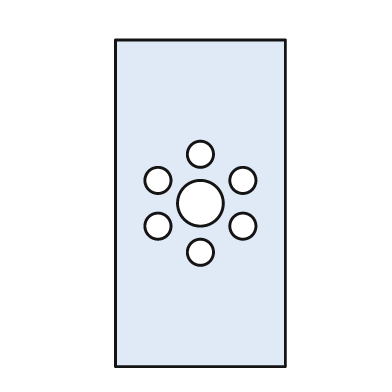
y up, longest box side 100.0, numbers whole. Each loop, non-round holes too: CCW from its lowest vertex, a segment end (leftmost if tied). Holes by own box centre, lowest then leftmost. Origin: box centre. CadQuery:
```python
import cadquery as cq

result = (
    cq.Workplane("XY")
    .moveTo(-26.0, -50.0)
    .lineTo(26.0, -50.0)
    .lineTo(26.0, 50.0)
    .lineTo(-26.0, 50.0)
    .close()
    .moveTo(0.0, -15.0)
    .circle(4.0)
    .moveTo(-13.0, -7.0)
    .circle(4.0)
    .moveTo(13.0, -7.0)
    .circle(4.0)
    .moveTo(0.0, 0.0)
    .circle(7.0)
    .moveTo(-13.0, 7.0)
    .circle(4.0)
    .moveTo(13.0, 7.0)
    .circle(4.0)
    .moveTo(0.0, 15.0)
    .circle(4.0)
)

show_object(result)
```